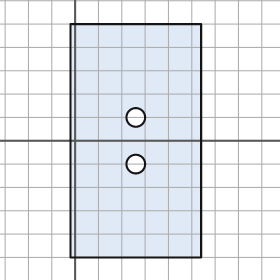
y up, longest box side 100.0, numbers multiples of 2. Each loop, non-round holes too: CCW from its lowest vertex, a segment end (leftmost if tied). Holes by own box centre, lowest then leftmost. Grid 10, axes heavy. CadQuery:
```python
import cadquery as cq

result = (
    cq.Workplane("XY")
    .moveTo(-2.0, -50.0)
    .lineTo(54.0, -50.0)
    .lineTo(54.0, 50.0)
    .lineTo(-2.0, 50.0)
    .close()
    .moveTo(26.0, -10.0)
    .circle(4.0)
    .moveTo(26.0, 10.0)
    .circle(4.0)
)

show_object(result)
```